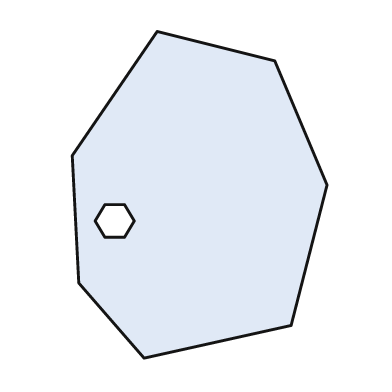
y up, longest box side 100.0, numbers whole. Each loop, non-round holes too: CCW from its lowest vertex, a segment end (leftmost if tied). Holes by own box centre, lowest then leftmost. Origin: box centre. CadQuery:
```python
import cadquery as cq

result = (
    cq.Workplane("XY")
    .moveTo(-17.0, -50.0)
    .lineTo(28.0, -40.0)
    .lineTo(39.0, 3.0)
    .lineTo(23.0, 41.0)
    .lineTo(-13.0, 50.0)
    .lineTo(-39.0, 12.0)
    .lineTo(-37.0, -27.0)
    .close()
    .moveTo(-29.0, -13.0)
    .lineTo(-23.0, -13.0)
    .lineTo(-20.0, -8.0)
    .lineTo(-23.0, -3.0)
    .lineTo(-29.0, -3.0)
    .lineTo(-32.0, -8.0)
    .close()
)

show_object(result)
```